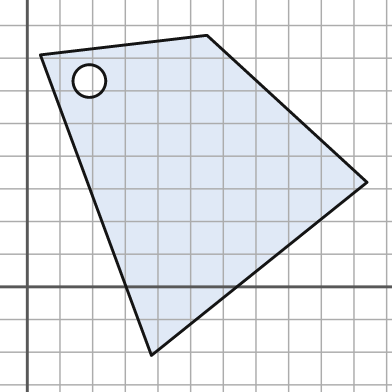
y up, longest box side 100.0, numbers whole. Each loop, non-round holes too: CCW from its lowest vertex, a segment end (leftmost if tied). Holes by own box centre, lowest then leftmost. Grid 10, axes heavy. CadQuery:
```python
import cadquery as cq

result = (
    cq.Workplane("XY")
    .moveTo(38.0, -21.0)
    .lineTo(104.0, 32.0)
    .lineTo(55.0, 77.0)
    .lineTo(4.0, 71.0)
    .close()
    .moveTo(19.0, 63.0)
    .circle(5.0)
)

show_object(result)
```